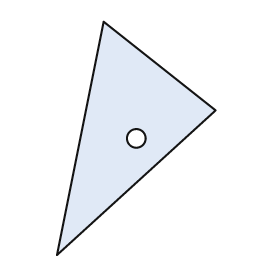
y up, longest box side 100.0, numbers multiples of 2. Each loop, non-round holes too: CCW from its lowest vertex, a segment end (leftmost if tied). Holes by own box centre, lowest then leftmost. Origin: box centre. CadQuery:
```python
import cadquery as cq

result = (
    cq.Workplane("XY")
    .moveTo(-34.0, -50.0)
    .lineTo(34.0, 12.0)
    .lineTo(-14.0, 50.0)
    .close()
    .moveTo(0.0, 0.0)
    .circle(4.0)
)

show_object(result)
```